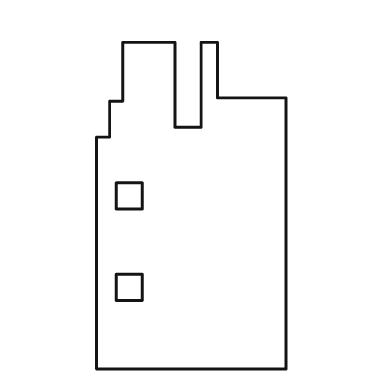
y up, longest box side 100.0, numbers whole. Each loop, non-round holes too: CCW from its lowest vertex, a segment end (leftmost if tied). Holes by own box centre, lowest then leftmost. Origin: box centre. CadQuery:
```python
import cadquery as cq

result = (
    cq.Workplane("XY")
    .moveTo(-29.0, -50.0)
    .lineTo(29.0, -50.0)
    .lineTo(29.0, 33.0)
    .lineTo(8.0, 33.0)
    .lineTo(8.0, 50.0)
    .lineTo(3.0, 50.0)
    .lineTo(3.0, 24.0)
    .lineTo(-5.0, 24.0)
    .lineTo(-5.0, 50.0)
    .lineTo(-21.0, 50.0)
    .lineTo(-21.0, 32.0)
    .lineTo(-25.0, 32.0)
    .lineTo(-25.0, 21.0)
    .lineTo(-29.0, 21.0)
    .close()
    .moveTo(-23.0, -29.0)
    .lineTo(-15.0, -29.0)
    .lineTo(-15.0, -21.0)
    .lineTo(-23.0, -21.0)
    .close()
    .moveTo(-23.0, -1.0)
    .lineTo(-15.0, -1.0)
    .lineTo(-15.0, 7.0)
    .lineTo(-23.0, 7.0)
    .close()
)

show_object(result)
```